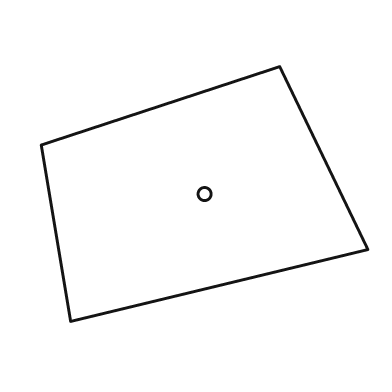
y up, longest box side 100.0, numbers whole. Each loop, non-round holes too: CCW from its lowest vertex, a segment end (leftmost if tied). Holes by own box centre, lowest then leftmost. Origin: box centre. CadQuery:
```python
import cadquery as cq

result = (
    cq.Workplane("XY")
    .moveTo(-41.0, -39.0)
    .lineTo(50.0, -17.0)
    .lineTo(23.0, 39.0)
    .lineTo(-50.0, 15.0)
    .close()
    .moveTo(0.0, 0.0)
    .circle(2.0)
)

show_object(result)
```